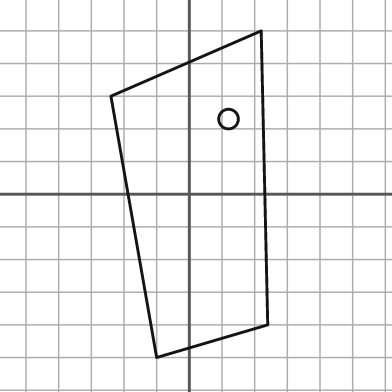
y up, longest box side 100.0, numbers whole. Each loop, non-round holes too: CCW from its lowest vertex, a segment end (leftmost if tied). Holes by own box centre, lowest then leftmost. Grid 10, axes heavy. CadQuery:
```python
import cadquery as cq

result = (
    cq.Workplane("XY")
    .moveTo(-10.0, -50.0)
    .lineTo(24.0, -40.0)
    .lineTo(22.0, 50.0)
    .lineTo(-24.0, 30.0)
    .close()
    .moveTo(12.0, 23.0)
    .circle(3.0)
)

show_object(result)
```